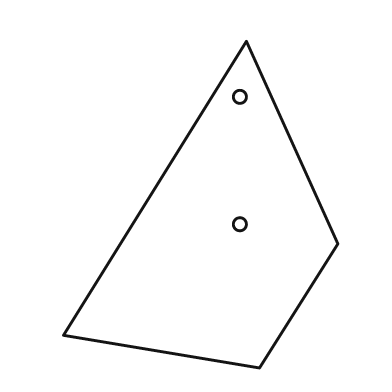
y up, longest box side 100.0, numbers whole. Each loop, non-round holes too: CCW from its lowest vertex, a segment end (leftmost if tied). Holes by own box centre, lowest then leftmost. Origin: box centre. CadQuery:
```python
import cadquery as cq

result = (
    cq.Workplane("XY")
    .moveTo(18.0, -50.0)
    .lineTo(42.0, -12.0)
    .lineTo(14.0, 50.0)
    .lineTo(-42.0, -40.0)
    .close()
    .moveTo(12.0, -6.0)
    .circle(2.0)
    .moveTo(12.0, 33.0)
    .circle(2.0)
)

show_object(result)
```